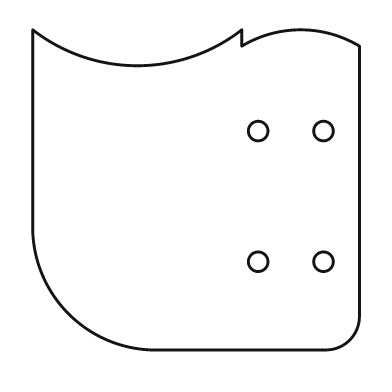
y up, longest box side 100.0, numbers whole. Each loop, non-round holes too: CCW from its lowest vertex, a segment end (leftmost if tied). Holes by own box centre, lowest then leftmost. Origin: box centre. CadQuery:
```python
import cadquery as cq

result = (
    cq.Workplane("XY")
    .moveTo(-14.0, -49.0)
    .lineTo(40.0, -49.0)
    .threePointArc((47.0, -46.0), (50.0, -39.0))
    .lineTo(50.0, 44.0)
    .threePointArc((32.0, 49.0), (14.0, 44.0))
    .lineTo(14.0, 49.0)
    .threePointArc((-18.0, 38.0), (-50.0, 49.0))
    .lineTo(-50.0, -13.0)
    .threePointArc((-39.0, -38.0), (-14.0, -49.0))
    .close()
    .moveTo(19.0, -22.0)
    .circle(3.0)
    .moveTo(39.0, -22.0)
    .circle(3.0)
    .moveTo(19.0, 18.0)
    .circle(3.0)
    .moveTo(39.0, 18.0)
    .circle(3.0)
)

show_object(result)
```